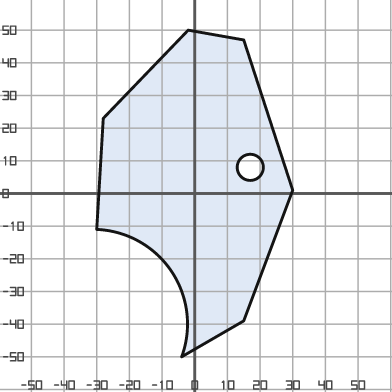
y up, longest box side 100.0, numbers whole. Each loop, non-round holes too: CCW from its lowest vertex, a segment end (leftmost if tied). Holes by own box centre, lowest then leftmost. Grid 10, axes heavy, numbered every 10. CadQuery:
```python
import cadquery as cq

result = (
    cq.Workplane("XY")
    .moveTo(-4.0, -50.0)
    .lineTo(15.0, -39.0)
    .lineTo(30.0, 1.0)
    .lineTo(15.0, 47.0)
    .lineTo(-2.0, 50.0)
    .lineTo(-28.0, 23.0)
    .lineTo(-30.0, -11.0)
    .threePointArc((-7.0, -24.0), (-4.0, -50.0))
    .close()
    .moveTo(17.0, 8.0)
    .circle(4.0)
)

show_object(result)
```